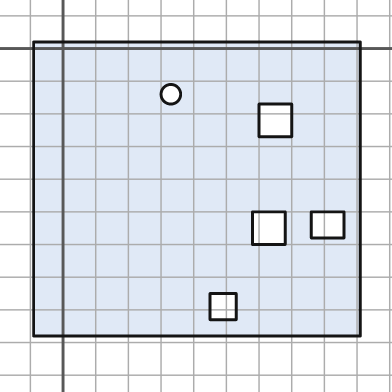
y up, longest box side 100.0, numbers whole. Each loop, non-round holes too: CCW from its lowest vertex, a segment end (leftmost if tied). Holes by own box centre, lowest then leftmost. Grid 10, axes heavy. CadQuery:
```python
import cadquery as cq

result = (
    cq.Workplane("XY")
    .moveTo(-9.0, -88.0)
    .lineTo(91.0, -88.0)
    .lineTo(91.0, 2.0)
    .lineTo(-9.0, 2.0)
    .close()
    .moveTo(45.0, -83.0)
    .lineTo(53.0, -83.0)
    .lineTo(53.0, -75.0)
    .lineTo(45.0, -75.0)
    .close()
    .moveTo(58.0, -60.0)
    .lineTo(68.0, -60.0)
    .lineTo(68.0, -50.0)
    .lineTo(58.0, -50.0)
    .close()
    .moveTo(76.0, -58.0)
    .lineTo(86.0, -58.0)
    .lineTo(86.0, -50.0)
    .lineTo(76.0, -50.0)
    .close()
    .moveTo(60.0, -27.0)
    .lineTo(70.0, -27.0)
    .lineTo(70.0, -17.0)
    .lineTo(60.0, -17.0)
    .close()
    .moveTo(33.0, -14.0)
    .circle(3.0)
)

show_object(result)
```